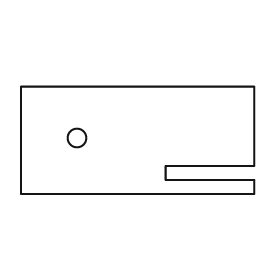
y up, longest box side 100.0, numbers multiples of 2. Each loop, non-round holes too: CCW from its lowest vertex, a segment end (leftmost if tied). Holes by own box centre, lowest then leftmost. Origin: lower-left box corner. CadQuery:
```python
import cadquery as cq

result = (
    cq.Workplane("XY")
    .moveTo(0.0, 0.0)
    .lineTo(100.0, 0.0)
    .lineTo(100.0, 6.0)
    .lineTo(62.0, 6.0)
    .lineTo(62.0, 12.0)
    .lineTo(100.0, 12.0)
    .lineTo(100.0, 46.0)
    .lineTo(0.0, 46.0)
    .close()
    .moveTo(24.0, 24.0)
    .circle(4.0)
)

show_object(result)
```